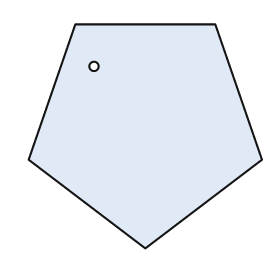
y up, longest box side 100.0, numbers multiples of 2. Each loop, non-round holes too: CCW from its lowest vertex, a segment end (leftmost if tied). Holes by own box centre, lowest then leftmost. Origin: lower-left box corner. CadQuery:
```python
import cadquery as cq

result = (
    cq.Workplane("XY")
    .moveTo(50.0, 0.0)
    .lineTo(100.0, 38.0)
    .lineTo(80.0, 96.0)
    .lineTo(20.0, 96.0)
    .lineTo(0.0, 38.0)
    .close()
    .moveTo(28.0, 78.0)
    .circle(2.0)
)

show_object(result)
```